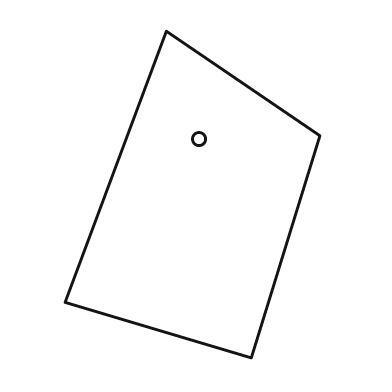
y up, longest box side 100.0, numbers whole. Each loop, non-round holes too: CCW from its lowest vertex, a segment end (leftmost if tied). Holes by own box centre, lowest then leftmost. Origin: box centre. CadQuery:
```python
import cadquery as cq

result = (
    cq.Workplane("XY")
    .moveTo(18.0, -50.0)
    .lineTo(39.0, 18.0)
    .lineTo(-8.0, 50.0)
    .lineTo(-39.0, -33.0)
    .close()
    .moveTo(2.0, 17.0)
    .circle(2.0)
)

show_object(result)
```